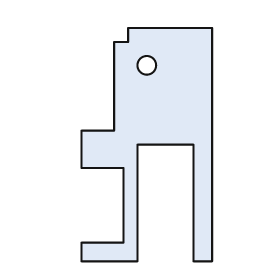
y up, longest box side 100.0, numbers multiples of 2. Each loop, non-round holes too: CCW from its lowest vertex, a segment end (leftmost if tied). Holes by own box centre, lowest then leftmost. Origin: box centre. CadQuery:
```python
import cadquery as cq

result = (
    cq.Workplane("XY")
    .moveTo(-28.0, -50.0)
    .lineTo(-4.0, -50.0)
    .lineTo(-4.0, 0.0)
    .lineTo(20.0, 0.0)
    .lineTo(20.0, -50.0)
    .lineTo(28.0, -50.0)
    .lineTo(28.0, 50.0)
    .lineTo(-8.0, 50.0)
    .lineTo(-8.0, 44.0)
    .lineTo(-14.0, 44.0)
    .lineTo(-14.0, 6.0)
    .lineTo(-28.0, 6.0)
    .lineTo(-28.0, -10.0)
    .lineTo(-10.0, -10.0)
    .lineTo(-10.0, -42.0)
    .lineTo(-28.0, -42.0)
    .close()
    .moveTo(0.0, 34.0)
    .circle(4.0)
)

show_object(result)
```